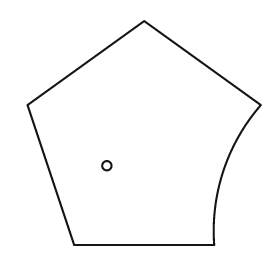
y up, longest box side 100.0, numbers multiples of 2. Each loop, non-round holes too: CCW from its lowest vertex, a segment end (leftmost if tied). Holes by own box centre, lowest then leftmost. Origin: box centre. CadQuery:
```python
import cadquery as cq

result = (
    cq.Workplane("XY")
    .moveTo(-30.0, -48.0)
    .lineTo(30.0, -48.0)
    .threePointArc((34.0, -16.0), (50.0, 12.0))
    .lineTo(0.0, 48.0)
    .lineTo(-50.0, 12.0)
    .close()
    .moveTo(-16.0, -14.0)
    .circle(2.0)
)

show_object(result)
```